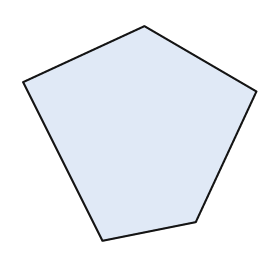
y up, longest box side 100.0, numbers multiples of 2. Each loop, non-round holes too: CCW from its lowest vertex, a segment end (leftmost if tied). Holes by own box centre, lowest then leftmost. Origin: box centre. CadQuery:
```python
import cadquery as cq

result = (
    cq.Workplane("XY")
    .moveTo(-16.0, -46.0)
    .lineTo(24.0, -38.0)
    .lineTo(50.0, 18.0)
    .lineTo(2.0, 46.0)
    .lineTo(-50.0, 22.0)
    .close()
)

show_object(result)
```